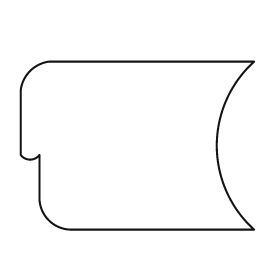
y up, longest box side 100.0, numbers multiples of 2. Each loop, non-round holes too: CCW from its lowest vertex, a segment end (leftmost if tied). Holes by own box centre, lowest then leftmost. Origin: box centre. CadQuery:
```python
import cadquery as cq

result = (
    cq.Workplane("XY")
    .moveTo(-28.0, -36.0)
    .lineTo(50.0, -36.0)
    .threePointArc((34.0, 0.0), (50.0, 36.0))
    .lineTo(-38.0, 36.0)
    .threePointArc((-46.0, 32.0), (-50.0, 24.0))
    .lineTo(-50.0, -4.0)
    .threePointArc((-46.0, -6.0), (-42.0, -4.0))
    .lineTo(-42.0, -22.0)
    .threePointArc((-38.0, -32.0), (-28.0, -36.0))
    .close()
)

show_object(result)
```